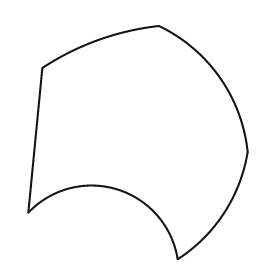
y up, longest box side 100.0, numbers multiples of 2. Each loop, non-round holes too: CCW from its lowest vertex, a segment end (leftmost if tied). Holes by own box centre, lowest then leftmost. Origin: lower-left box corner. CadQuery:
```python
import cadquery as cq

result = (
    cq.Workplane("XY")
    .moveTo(64.0, 0.0)
    .threePointArc((84.0, 20.0), (94.0, 46.0))
    .threePointArc((82.0, 78.0), (56.0, 100.0))
    .threePointArc((30.0, 94.0), (6.0, 82.0))
    .lineTo(0.0, 20.0)
    .threePointArc((38.0, 30.0), (64.0, 0.0))
    .close()
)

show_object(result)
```